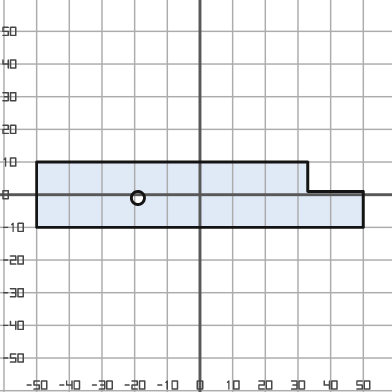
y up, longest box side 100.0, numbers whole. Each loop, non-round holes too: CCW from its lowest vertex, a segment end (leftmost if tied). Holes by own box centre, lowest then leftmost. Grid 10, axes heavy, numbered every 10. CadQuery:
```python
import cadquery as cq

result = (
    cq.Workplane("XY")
    .moveTo(-50.0, -10.0)
    .lineTo(50.0, -10.0)
    .lineTo(50.0, 1.0)
    .lineTo(33.0, 1.0)
    .lineTo(33.0, 10.0)
    .lineTo(-50.0, 10.0)
    .close()
    .moveTo(-19.0, -1.0)
    .circle(2.0)
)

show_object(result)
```